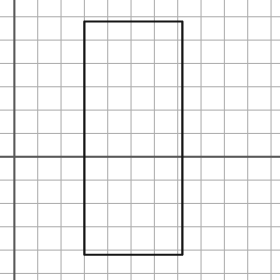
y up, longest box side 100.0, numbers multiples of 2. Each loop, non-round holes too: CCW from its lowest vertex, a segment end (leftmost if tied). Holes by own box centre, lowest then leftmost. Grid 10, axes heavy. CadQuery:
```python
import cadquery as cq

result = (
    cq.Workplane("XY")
    .moveTo(30.0, -42.0)
    .lineTo(72.0, -42.0)
    .lineTo(72.0, 58.0)
    .lineTo(30.0, 58.0)
    .close()
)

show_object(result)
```